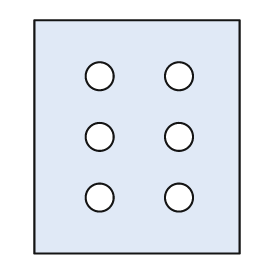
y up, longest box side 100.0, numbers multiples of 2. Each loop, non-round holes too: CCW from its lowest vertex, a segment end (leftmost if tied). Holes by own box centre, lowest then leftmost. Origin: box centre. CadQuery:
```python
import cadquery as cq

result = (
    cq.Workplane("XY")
    .moveTo(-44.0, -50.0)
    .lineTo(44.0, -50.0)
    .lineTo(44.0, 50.0)
    .lineTo(-44.0, 50.0)
    .close()
    .moveTo(-16.0, -26.0)
    .circle(6.0)
    .moveTo(18.0, -26.0)
    .circle(6.0)
    .moveTo(-16.0, 0.0)
    .circle(6.0)
    .moveTo(18.0, 0.0)
    .circle(6.0)
    .moveTo(-16.0, 26.0)
    .circle(6.0)
    .moveTo(18.0, 26.0)
    .circle(6.0)
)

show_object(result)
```